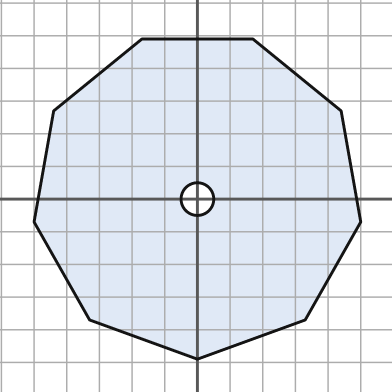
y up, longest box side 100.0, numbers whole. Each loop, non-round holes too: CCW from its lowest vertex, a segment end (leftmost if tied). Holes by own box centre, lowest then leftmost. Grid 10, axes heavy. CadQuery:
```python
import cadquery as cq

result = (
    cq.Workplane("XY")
    .moveTo(0.0, -49.0)
    .lineTo(33.0, -37.0)
    .lineTo(50.0, -7.0)
    .lineTo(44.0, 27.0)
    .lineTo(17.0, 49.0)
    .lineTo(-17.0, 49.0)
    .lineTo(-44.0, 27.0)
    .lineTo(-50.0, -7.0)
    .lineTo(-33.0, -37.0)
    .close()
    .moveTo(0.0, 0.0)
    .circle(5.0)
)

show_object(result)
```